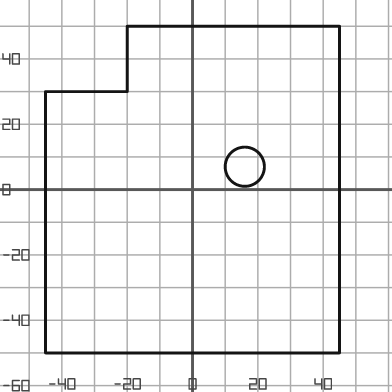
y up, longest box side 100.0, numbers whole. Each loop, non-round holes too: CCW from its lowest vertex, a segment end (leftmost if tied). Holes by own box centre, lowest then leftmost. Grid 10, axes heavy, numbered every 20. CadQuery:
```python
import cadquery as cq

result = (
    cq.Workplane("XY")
    .moveTo(-45.0, -50.0)
    .lineTo(45.0, -50.0)
    .lineTo(45.0, 50.0)
    .lineTo(-20.0, 50.0)
    .lineTo(-20.0, 30.0)
    .lineTo(-45.0, 30.0)
    .close()
    .moveTo(16.0, 7.0)
    .circle(6.0)
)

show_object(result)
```